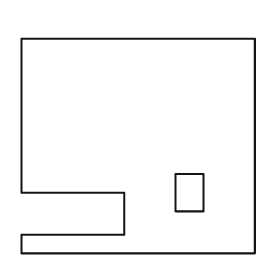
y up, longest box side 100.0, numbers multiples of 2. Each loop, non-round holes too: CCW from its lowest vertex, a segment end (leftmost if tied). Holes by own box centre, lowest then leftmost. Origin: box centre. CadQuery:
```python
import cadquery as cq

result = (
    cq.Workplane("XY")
    .moveTo(-50.0, -46.0)
    .lineTo(50.0, -46.0)
    .lineTo(50.0, 46.0)
    .lineTo(-50.0, 46.0)
    .lineTo(-50.0, -20.0)
    .lineTo(-6.0, -20.0)
    .lineTo(-6.0, -38.0)
    .lineTo(-50.0, -38.0)
    .close()
    .moveTo(16.0, -28.0)
    .lineTo(28.0, -28.0)
    .lineTo(28.0, -12.0)
    .lineTo(16.0, -12.0)
    .close()
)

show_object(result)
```